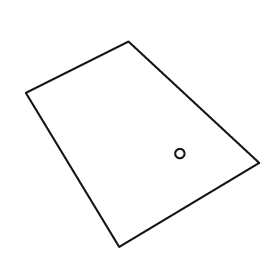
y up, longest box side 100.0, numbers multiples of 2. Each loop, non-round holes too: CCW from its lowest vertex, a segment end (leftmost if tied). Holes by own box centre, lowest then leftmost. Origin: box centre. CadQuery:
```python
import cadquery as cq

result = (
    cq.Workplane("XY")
    .moveTo(-10.0, -44.0)
    .lineTo(50.0, -8.0)
    .lineTo(-6.0, 44.0)
    .lineTo(-50.0, 22.0)
    .close()
    .moveTo(16.0, -4.0)
    .circle(2.0)
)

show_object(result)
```